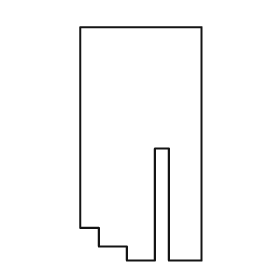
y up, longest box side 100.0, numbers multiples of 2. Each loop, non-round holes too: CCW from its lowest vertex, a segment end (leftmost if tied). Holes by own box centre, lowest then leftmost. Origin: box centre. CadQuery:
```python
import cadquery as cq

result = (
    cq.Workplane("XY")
    .moveTo(-6.0, -50.0)
    .lineTo(6.0, -50.0)
    .lineTo(6.0, -2.0)
    .lineTo(12.0, -2.0)
    .lineTo(12.0, -50.0)
    .lineTo(26.0, -50.0)
    .lineTo(26.0, 50.0)
    .lineTo(-26.0, 50.0)
    .lineTo(-26.0, -36.0)
    .lineTo(-18.0, -36.0)
    .lineTo(-18.0, -44.0)
    .lineTo(-6.0, -44.0)
    .close()
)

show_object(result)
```